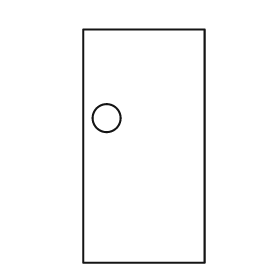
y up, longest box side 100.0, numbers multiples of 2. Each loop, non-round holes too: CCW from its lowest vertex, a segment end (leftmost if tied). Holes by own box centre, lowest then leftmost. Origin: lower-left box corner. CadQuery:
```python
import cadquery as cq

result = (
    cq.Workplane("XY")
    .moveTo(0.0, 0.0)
    .lineTo(52.0, 0.0)
    .lineTo(52.0, 100.0)
    .lineTo(0.0, 100.0)
    .close()
    .moveTo(10.0, 62.0)
    .circle(6.0)
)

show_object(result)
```